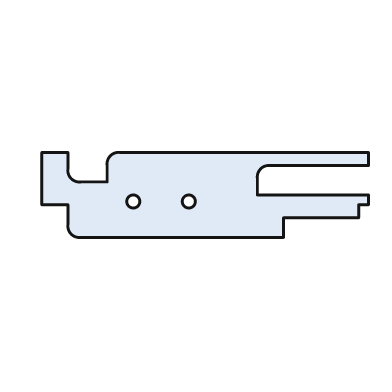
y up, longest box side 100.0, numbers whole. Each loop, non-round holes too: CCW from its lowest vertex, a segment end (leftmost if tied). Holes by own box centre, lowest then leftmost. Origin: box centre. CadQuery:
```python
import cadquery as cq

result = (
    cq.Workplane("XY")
    .moveTo(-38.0, -13.0)
    .lineTo(24.0, -13.0)
    .lineTo(24.0, -7.0)
    .lineTo(47.0, -7.0)
    .lineTo(47.0, -3.0)
    .lineTo(50.0, -3.0)
    .lineTo(50.0, 0.0)
    .lineTo(16.0, 0.0)
    .lineTo(16.0, 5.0)
    .threePointArc((17.0, 8.0), (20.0, 9.0))
    .lineTo(50.0, 9.0)
    .lineTo(50.0, 13.0)
    .lineTo(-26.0, 13.0)
    .threePointArc((-29.0, 12.0), (-30.0, 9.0))
    .lineTo(-30.0, 4.0)
    .lineTo(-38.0, 4.0)
    .threePointArc((-41.0, 5.0), (-42.0, 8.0))
    .lineTo(-42.0, 13.0)
    .lineTo(-50.0, 13.0)
    .lineTo(-50.0, -3.0)
    .lineTo(-42.0, -3.0)
    .lineTo(-42.0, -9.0)
    .threePointArc((-41.0, -12.0), (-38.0, -13.0))
    .close()
    .moveTo(-22.0, -2.0)
    .circle(2.0)
    .moveTo(-5.0, -2.0)
    .circle(2.0)
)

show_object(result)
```